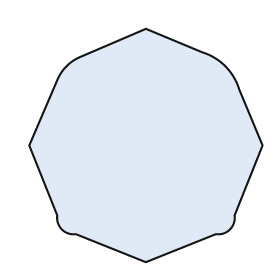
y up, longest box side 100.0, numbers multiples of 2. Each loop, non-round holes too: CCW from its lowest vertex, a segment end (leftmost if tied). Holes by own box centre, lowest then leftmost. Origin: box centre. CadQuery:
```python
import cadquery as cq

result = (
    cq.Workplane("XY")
    .moveTo(0.0, -50.0)
    .lineTo(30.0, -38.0)
    .threePointArc((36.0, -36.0), (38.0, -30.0))
    .lineTo(50.0, 0.0)
    .lineTo(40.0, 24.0)
    .threePointArc((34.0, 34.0), (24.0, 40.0))
    .lineTo(0.0, 50.0)
    .lineTo(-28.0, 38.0)
    .threePointArc((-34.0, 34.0), (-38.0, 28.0))
    .lineTo(-50.0, 0.0)
    .lineTo(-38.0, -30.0)
    .threePointArc((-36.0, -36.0), (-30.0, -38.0))
    .close()
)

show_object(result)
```